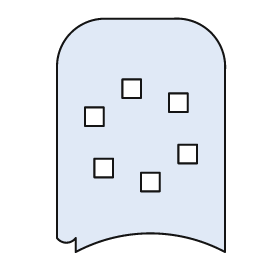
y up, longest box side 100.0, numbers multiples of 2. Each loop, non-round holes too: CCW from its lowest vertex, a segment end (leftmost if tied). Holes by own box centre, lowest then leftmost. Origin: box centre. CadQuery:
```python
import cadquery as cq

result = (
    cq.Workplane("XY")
    .moveTo(-28.0, -50.0)
    .threePointArc((4.0, -42.0), (36.0, -50.0))
    .lineTo(36.0, 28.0)
    .threePointArc((30.0, 44.0), (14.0, 50.0))
    .lineTo(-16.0, 50.0)
    .threePointArc((-30.0, 44.0), (-36.0, 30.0))
    .lineTo(-36.0, -44.0)
    .threePointArc((-32.0, -46.0), (-28.0, -44.0))
    .close()
    .moveTo(0.0, -24.0)
    .lineTo(8.0, -24.0)
    .lineTo(8.0, -16.0)
    .lineTo(0.0, -16.0)
    .close()
    .moveTo(-20.0, -18.0)
    .lineTo(-12.0, -18.0)
    .lineTo(-12.0, -10.0)
    .lineTo(-20.0, -10.0)
    .close()
    .moveTo(16.0, -12.0)
    .lineTo(24.0, -12.0)
    .lineTo(24.0, -4.0)
    .lineTo(16.0, -4.0)
    .close()
    .moveTo(-24.0, 4.0)
    .lineTo(-16.0, 4.0)
    .lineTo(-16.0, 12.0)
    .lineTo(-24.0, 12.0)
    .close()
    .moveTo(12.0, 10.0)
    .lineTo(20.0, 10.0)
    .lineTo(20.0, 18.0)
    .lineTo(12.0, 18.0)
    .close()
    .moveTo(-8.0, 16.0)
    .lineTo(0.0, 16.0)
    .lineTo(0.0, 24.0)
    .lineTo(-8.0, 24.0)
    .close()
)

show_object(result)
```